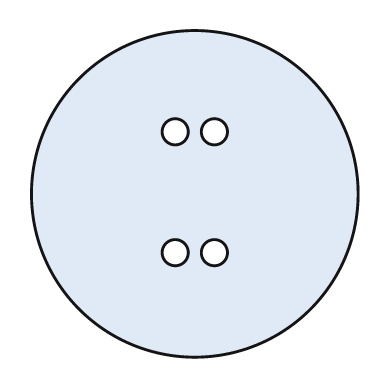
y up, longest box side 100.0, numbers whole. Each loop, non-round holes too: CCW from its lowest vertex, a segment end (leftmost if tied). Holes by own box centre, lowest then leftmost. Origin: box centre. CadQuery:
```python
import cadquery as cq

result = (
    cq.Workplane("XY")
    .moveTo(0.0, 0.0)
    .circle(50.0)
    .moveTo(-6.0, -18.0)
    .circle(4.0)
    .moveTo(6.0, -18.0)
    .circle(4.0)
    .moveTo(-6.0, 19.0)
    .circle(4.0)
    .moveTo(6.0, 19.0)
    .circle(4.0)
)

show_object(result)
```